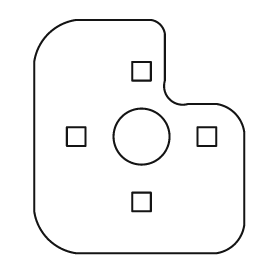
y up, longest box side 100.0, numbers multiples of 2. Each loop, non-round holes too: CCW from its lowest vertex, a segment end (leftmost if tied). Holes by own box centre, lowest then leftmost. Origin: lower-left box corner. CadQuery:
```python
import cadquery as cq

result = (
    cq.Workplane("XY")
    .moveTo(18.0, 0.0)
    .lineTo(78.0, 0.0)
    .threePointArc((86.0, 4.0), (90.0, 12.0))
    .lineTo(90.0, 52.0)
    .threePointArc((86.0, 60.0), (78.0, 64.0))
    .lineTo(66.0, 64.0)
    .threePointArc((58.0, 66.0), (56.0, 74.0))
    .lineTo(56.0, 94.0)
    .threePointArc((54.0, 98.0), (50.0, 100.0))
    .lineTo(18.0, 100.0)
    .threePointArc((6.0, 94.0), (0.0, 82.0))
    .lineTo(0.0, 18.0)
    .threePointArc((6.0, 6.0), (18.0, 0.0))
    .close()
    .moveTo(42.0, 18.0)
    .lineTo(50.0, 18.0)
    .lineTo(50.0, 26.0)
    .lineTo(42.0, 26.0)
    .close()
    .moveTo(14.0, 46.0)
    .lineTo(22.0, 46.0)
    .lineTo(22.0, 54.0)
    .lineTo(14.0, 54.0)
    .close()
    .moveTo(46.0, 50.0)
    .circle(12.0)
    .moveTo(70.0, 46.0)
    .lineTo(78.0, 46.0)
    .lineTo(78.0, 54.0)
    .lineTo(70.0, 54.0)
    .close()
    .moveTo(42.0, 74.0)
    .lineTo(50.0, 74.0)
    .lineTo(50.0, 82.0)
    .lineTo(42.0, 82.0)
    .close()
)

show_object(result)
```